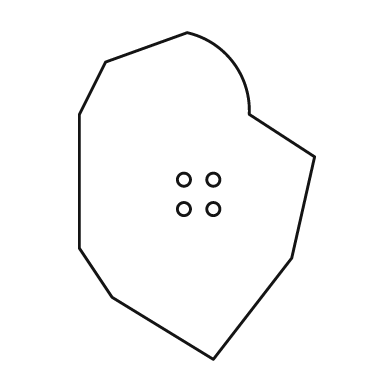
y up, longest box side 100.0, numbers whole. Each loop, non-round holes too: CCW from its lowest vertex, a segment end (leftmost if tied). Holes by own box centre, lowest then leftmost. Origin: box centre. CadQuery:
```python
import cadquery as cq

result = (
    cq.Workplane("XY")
    .moveTo(5.0, -50.0)
    .lineTo(29.0, -19.0)
    .lineTo(36.0, 12.0)
    .lineTo(16.0, 25.0)
    .threePointArc((11.0, 41.0), (-3.0, 50.0))
    .lineTo(-28.0, 41.0)
    .lineTo(-36.0, 25.0)
    .lineTo(-36.0, -16.0)
    .lineTo(-26.0, -31.0)
    .close()
    .moveTo(-4.0, -4.0)
    .circle(2.0)
    .moveTo(5.0, -4.0)
    .circle(2.0)
    .moveTo(-4.0, 5.0)
    .circle(2.0)
    .moveTo(5.0, 5.0)
    .circle(2.0)
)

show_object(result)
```